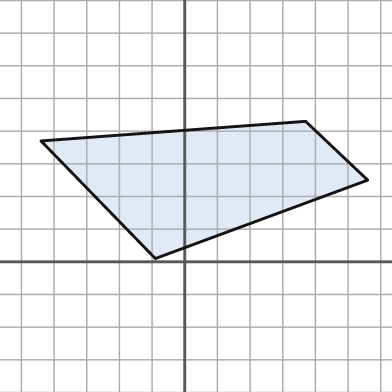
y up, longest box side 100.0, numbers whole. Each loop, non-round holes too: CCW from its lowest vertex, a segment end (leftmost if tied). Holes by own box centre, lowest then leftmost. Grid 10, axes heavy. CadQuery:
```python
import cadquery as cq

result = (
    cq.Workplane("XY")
    .moveTo(-9.0, 1.0)
    .lineTo(56.0, 25.0)
    .lineTo(37.0, 43.0)
    .lineTo(-44.0, 37.0)
    .close()
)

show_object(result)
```